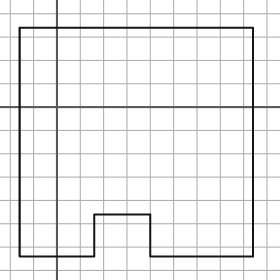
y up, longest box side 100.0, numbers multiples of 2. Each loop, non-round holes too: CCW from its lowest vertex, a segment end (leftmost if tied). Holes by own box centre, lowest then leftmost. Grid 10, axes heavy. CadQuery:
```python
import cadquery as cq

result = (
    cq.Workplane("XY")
    .moveTo(-16.0, -64.0)
    .lineTo(16.0, -64.0)
    .lineTo(16.0, -46.0)
    .lineTo(40.0, -46.0)
    .lineTo(40.0, -64.0)
    .lineTo(84.0, -64.0)
    .lineTo(84.0, 34.0)
    .lineTo(-16.0, 34.0)
    .close()
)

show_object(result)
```